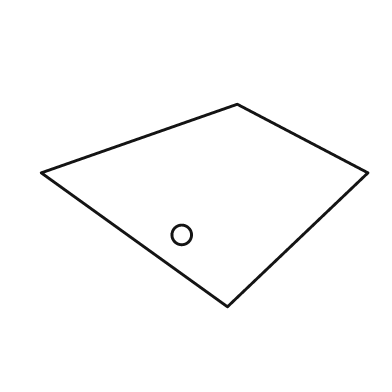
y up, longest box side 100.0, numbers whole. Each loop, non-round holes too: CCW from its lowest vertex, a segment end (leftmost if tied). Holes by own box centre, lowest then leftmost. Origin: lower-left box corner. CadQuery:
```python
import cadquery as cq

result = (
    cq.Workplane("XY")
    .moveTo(57.0, 0.0)
    .lineTo(100.0, 41.0)
    .lineTo(60.0, 62.0)
    .lineTo(0.0, 41.0)
    .close()
    .moveTo(43.0, 22.0)
    .circle(3.0)
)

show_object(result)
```